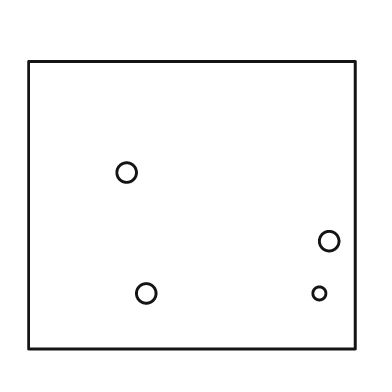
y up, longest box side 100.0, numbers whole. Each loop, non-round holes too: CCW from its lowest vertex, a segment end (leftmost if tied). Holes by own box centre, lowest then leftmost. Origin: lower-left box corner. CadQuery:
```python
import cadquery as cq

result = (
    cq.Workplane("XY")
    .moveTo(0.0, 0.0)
    .lineTo(100.0, 0.0)
    .lineTo(100.0, 88.0)
    .lineTo(0.0, 88.0)
    .close()
    .moveTo(36.0, 17.0)
    .circle(3.0)
    .moveTo(89.0, 17.0)
    .circle(2.0)
    .moveTo(92.0, 33.0)
    .circle(3.0)
    .moveTo(30.0, 54.0)
    .circle(3.0)
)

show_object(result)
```